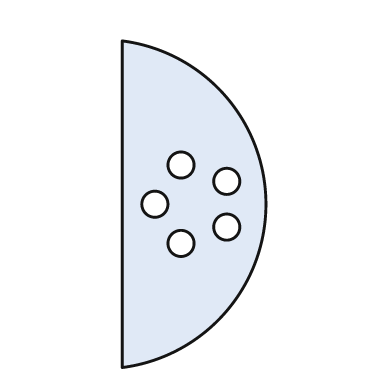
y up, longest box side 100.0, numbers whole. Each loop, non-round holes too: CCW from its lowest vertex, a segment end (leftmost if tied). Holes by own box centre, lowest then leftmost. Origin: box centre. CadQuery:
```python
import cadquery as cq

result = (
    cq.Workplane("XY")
    .moveTo(-22.0, -50.0)
    .threePointArc((22.0, 0.0), (-22.0, 50.0))
    .close()
    .moveTo(-4.0, -12.0)
    .circle(4.0)
    .moveTo(10.0, -7.0)
    .circle(4.0)
    .moveTo(-12.0, 0.0)
    .circle(4.0)
    .moveTo(10.0, 7.0)
    .circle(4.0)
    .moveTo(-4.0, 12.0)
    .circle(4.0)
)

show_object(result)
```